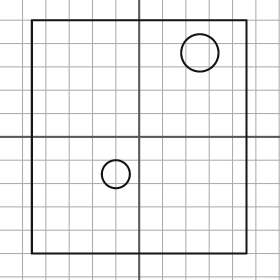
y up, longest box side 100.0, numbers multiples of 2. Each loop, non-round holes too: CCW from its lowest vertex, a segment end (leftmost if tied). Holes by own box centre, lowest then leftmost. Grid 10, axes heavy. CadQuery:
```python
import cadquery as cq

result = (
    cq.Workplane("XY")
    .moveTo(-46.0, -50.0)
    .lineTo(46.0, -50.0)
    .lineTo(46.0, 50.0)
    .lineTo(-46.0, 50.0)
    .close()
    .moveTo(-10.0, -16.0)
    .circle(6.0)
    .moveTo(26.0, 36.0)
    .circle(8.0)
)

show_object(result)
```